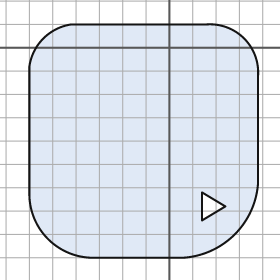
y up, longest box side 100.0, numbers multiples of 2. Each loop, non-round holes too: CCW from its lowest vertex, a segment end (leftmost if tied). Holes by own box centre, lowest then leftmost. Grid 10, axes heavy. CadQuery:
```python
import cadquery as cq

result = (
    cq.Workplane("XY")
    .moveTo(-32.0, -90.0)
    .lineTo(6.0, -90.0)
    .threePointArc((28.0, -80.0), (38.0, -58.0))
    .lineTo(38.0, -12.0)
    .threePointArc((32.0, 4.0), (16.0, 10.0))
    .lineTo(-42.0, 10.0)
    .threePointArc((-54.0, 4.0), (-60.0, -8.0))
    .lineTo(-60.0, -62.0)
    .threePointArc((-52.0, -82.0), (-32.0, -90.0))
    .close()
    .moveTo(14.0, -74.0)
    .lineTo(24.0, -68.0)
    .lineTo(14.0, -62.0)
    .close()
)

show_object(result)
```